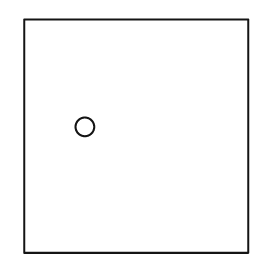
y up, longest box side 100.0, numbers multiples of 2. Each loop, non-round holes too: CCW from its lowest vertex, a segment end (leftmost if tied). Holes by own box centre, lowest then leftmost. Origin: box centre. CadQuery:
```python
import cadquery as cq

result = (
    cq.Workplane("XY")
    .moveTo(-48.0, -50.0)
    .lineTo(48.0, -50.0)
    .lineTo(48.0, 50.0)
    .lineTo(-48.0, 50.0)
    .close()
    .moveTo(-22.0, 4.0)
    .circle(4.0)
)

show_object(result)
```